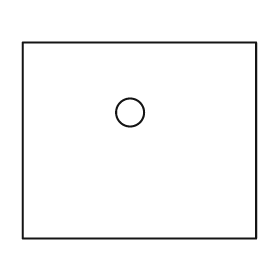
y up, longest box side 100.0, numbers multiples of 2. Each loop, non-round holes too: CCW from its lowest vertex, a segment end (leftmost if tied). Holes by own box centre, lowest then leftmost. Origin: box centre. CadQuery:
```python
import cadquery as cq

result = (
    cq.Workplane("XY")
    .moveTo(-50.0, -42.0)
    .lineTo(50.0, -42.0)
    .lineTo(50.0, 42.0)
    .lineTo(-50.0, 42.0)
    .close()
    .moveTo(-4.0, 12.0)
    .circle(6.0)
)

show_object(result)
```